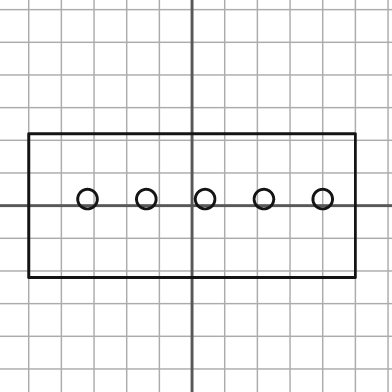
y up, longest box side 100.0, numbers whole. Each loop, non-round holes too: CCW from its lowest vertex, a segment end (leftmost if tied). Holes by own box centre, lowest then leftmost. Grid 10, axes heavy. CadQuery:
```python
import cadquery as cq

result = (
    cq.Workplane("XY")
    .moveTo(-50.0, -22.0)
    .lineTo(50.0, -22.0)
    .lineTo(50.0, 22.0)
    .lineTo(-50.0, 22.0)
    .close()
    .moveTo(-32.0, 2.0)
    .circle(3.0)
    .moveTo(-14.0, 2.0)
    .circle(3.0)
    .moveTo(4.0, 2.0)
    .circle(3.0)
    .moveTo(22.0, 2.0)
    .circle(3.0)
    .moveTo(40.0, 2.0)
    .circle(3.0)
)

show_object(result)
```